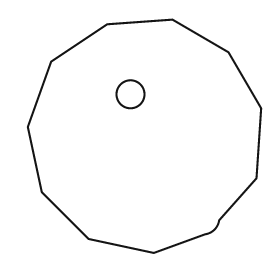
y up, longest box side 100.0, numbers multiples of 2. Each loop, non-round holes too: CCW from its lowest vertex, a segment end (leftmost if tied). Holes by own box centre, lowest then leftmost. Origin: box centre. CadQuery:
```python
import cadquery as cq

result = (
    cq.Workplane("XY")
    .moveTo(4.0, -50.0)
    .lineTo(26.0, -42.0)
    .threePointArc((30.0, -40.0), (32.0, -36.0))
    .lineTo(48.0, -18.0)
    .lineTo(50.0, 12.0)
    .lineTo(36.0, 36.0)
    .lineTo(12.0, 50.0)
    .lineTo(-16.0, 48.0)
    .lineTo(-40.0, 32.0)
    .lineTo(-50.0, 4.0)
    .lineTo(-44.0, -24.0)
    .lineTo(-24.0, -44.0)
    .close()
    .moveTo(-6.0, 18.0)
    .circle(6.0)
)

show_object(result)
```